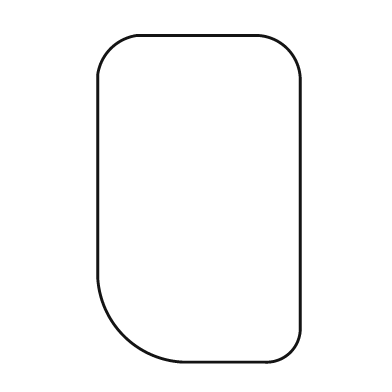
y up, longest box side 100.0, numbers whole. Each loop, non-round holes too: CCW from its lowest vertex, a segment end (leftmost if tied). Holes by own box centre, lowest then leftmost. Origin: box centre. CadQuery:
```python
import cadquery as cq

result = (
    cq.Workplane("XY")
    .moveTo(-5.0, -50.0)
    .lineTo(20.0, -50.0)
    .threePointArc((28.0, -47.0), (31.0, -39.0))
    .lineTo(31.0, 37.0)
    .threePointArc((27.0, 46.0), (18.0, 50.0))
    .lineTo(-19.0, 50.0)
    .threePointArc((-27.0, 46.0), (-31.0, 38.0))
    .lineTo(-31.0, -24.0)
    .threePointArc((-23.0, -42.0), (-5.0, -50.0))
    .close()
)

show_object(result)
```